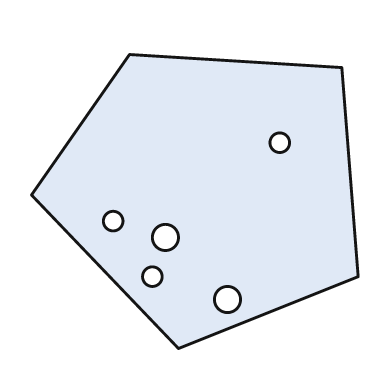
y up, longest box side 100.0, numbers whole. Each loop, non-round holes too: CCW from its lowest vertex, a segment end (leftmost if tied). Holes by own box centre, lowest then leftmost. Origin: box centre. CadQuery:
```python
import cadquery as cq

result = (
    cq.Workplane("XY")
    .moveTo(-5.0, -45.0)
    .lineTo(50.0, -23.0)
    .lineTo(45.0, 41.0)
    .lineTo(-20.0, 45.0)
    .lineTo(-50.0, 2.0)
    .close()
    .moveTo(10.0, -30.0)
    .circle(4.0)
    .moveTo(-13.0, -23.0)
    .circle(3.0)
    .moveTo(-9.0, -11.0)
    .circle(4.0)
    .moveTo(-25.0, -6.0)
    .circle(3.0)
    .moveTo(26.0, 18.0)
    .circle(3.0)
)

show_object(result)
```